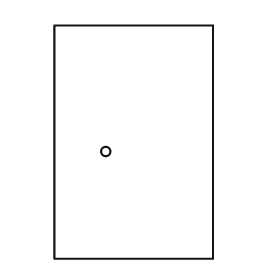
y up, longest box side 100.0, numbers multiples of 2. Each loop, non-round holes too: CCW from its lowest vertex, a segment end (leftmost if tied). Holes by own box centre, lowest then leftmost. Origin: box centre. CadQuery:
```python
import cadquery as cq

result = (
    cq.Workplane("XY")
    .moveTo(-34.0, -50.0)
    .lineTo(34.0, -50.0)
    .lineTo(34.0, 50.0)
    .lineTo(-34.0, 50.0)
    .close()
    .moveTo(-12.0, -4.0)
    .circle(2.0)
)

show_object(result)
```